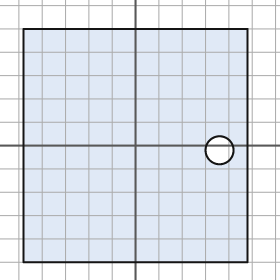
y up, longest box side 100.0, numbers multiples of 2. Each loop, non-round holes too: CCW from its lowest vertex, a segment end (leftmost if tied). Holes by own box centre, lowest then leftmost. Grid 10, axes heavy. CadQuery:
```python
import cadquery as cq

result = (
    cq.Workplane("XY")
    .moveTo(-48.0, -50.0)
    .lineTo(48.0, -50.0)
    .lineTo(48.0, 50.0)
    .lineTo(-48.0, 50.0)
    .close()
    .moveTo(36.0, -2.0)
    .circle(6.0)
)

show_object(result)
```